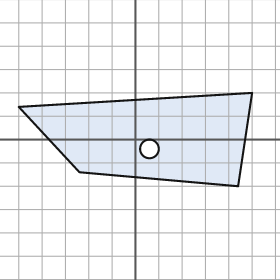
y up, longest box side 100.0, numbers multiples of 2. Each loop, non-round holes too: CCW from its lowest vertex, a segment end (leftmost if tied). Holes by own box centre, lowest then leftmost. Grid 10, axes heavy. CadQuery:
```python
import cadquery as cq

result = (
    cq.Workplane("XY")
    .moveTo(44.0, -20.0)
    .lineTo(50.0, 20.0)
    .lineTo(-50.0, 14.0)
    .lineTo(-24.0, -14.0)
    .close()
    .moveTo(6.0, -4.0)
    .circle(4.0)
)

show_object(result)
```